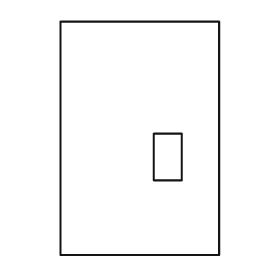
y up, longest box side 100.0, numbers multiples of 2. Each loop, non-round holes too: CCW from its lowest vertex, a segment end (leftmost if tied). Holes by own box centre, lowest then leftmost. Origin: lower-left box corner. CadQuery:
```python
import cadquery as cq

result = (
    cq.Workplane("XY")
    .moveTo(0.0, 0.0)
    .lineTo(68.0, 0.0)
    .lineTo(68.0, 100.0)
    .lineTo(0.0, 100.0)
    .close()
    .moveTo(40.0, 32.0)
    .lineTo(52.0, 32.0)
    .lineTo(52.0, 52.0)
    .lineTo(40.0, 52.0)
    .close()
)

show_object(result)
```